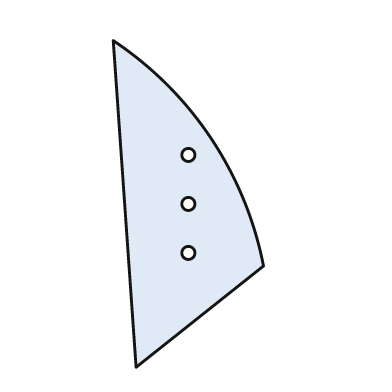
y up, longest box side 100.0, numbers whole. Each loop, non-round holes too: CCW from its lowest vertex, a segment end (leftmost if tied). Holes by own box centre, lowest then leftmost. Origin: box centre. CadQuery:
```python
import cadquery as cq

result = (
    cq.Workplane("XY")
    .moveTo(-16.0, -50.0)
    .lineTo(23.0, -19.0)
    .threePointArc((7.0, 20.0), (-23.0, 50.0))
    .close()
    .moveTo(0.0, -15.0)
    .circle(2.0)
    .moveTo(0.0, 0.0)
    .circle(2.0)
    .moveTo(0.0, 15.0)
    .circle(2.0)
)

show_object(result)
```